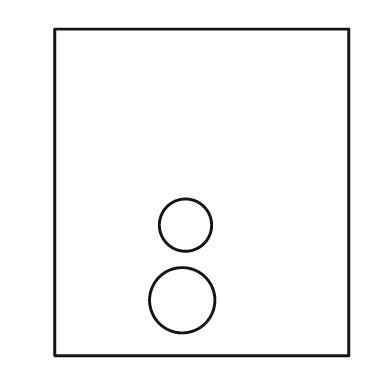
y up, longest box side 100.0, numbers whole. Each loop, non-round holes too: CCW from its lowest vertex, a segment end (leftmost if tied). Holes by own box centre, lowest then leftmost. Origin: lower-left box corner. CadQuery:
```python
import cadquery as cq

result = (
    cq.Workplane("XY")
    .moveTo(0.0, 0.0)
    .lineTo(90.0, 0.0)
    .lineTo(90.0, 100.0)
    .lineTo(0.0, 100.0)
    .close()
    .moveTo(39.0, 17.0)
    .circle(10.0)
    .moveTo(40.0, 40.0)
    .circle(8.0)
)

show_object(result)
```